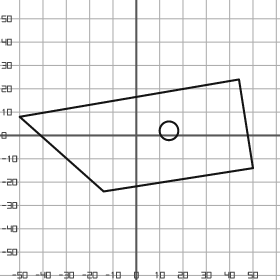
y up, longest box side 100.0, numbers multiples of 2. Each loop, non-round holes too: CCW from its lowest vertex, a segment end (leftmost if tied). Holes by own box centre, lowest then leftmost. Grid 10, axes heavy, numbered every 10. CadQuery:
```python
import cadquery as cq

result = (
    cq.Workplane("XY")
    .moveTo(-14.0, -24.0)
    .lineTo(50.0, -14.0)
    .lineTo(44.0, 24.0)
    .lineTo(-50.0, 8.0)
    .close()
    .moveTo(14.0, 2.0)
    .circle(4.0)
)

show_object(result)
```